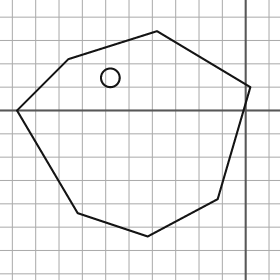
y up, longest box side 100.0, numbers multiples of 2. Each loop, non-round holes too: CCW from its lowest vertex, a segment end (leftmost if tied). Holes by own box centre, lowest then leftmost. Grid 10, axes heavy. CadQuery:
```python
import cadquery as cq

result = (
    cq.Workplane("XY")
    .moveTo(-42.0, -54.0)
    .lineTo(-12.0, -38.0)
    .lineTo(2.0, 10.0)
    .lineTo(-38.0, 34.0)
    .lineTo(-76.0, 22.0)
    .lineTo(-98.0, 0.0)
    .lineTo(-72.0, -44.0)
    .close()
    .moveTo(-58.0, 14.0)
    .circle(4.0)
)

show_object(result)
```